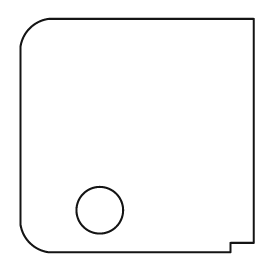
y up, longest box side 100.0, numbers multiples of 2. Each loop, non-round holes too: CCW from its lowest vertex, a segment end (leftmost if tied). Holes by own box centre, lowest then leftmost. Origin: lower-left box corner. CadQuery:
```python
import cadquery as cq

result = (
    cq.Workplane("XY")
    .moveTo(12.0, 0.0)
    .lineTo(90.0, 0.0)
    .lineTo(90.0, 4.0)
    .lineTo(100.0, 4.0)
    .lineTo(100.0, 100.0)
    .lineTo(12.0, 100.0)
    .threePointArc((4.0, 96.0), (0.0, 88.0))
    .lineTo(0.0, 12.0)
    .threePointArc((4.0, 4.0), (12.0, 0.0))
    .close()
    .moveTo(34.0, 18.0)
    .circle(10.0)
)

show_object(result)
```